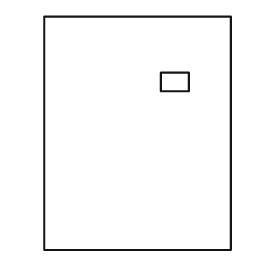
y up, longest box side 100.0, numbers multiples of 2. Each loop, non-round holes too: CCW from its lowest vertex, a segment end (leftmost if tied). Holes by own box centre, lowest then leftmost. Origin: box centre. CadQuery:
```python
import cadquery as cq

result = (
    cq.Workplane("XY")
    .moveTo(-40.0, -50.0)
    .lineTo(40.0, -50.0)
    .lineTo(40.0, 50.0)
    .lineTo(-40.0, 50.0)
    .close()
    .moveTo(10.0, 18.0)
    .lineTo(22.0, 18.0)
    .lineTo(22.0, 26.0)
    .lineTo(10.0, 26.0)
    .close()
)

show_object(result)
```